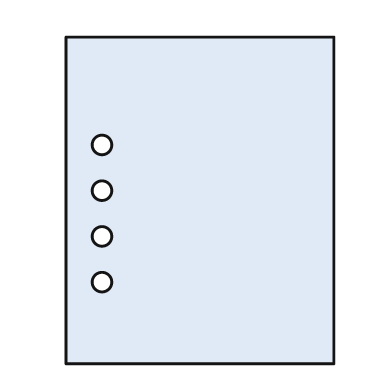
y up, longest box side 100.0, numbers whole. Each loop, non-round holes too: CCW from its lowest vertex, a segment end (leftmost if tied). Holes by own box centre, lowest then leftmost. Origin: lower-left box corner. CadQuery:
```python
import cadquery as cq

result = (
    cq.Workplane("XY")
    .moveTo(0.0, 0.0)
    .lineTo(82.0, 0.0)
    .lineTo(82.0, 100.0)
    .lineTo(0.0, 100.0)
    .close()
    .moveTo(11.0, 25.0)
    .circle(3.0)
    .moveTo(11.0, 39.0)
    .circle(3.0)
    .moveTo(11.0, 53.0)
    .circle(3.0)
    .moveTo(11.0, 67.0)
    .circle(3.0)
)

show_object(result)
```